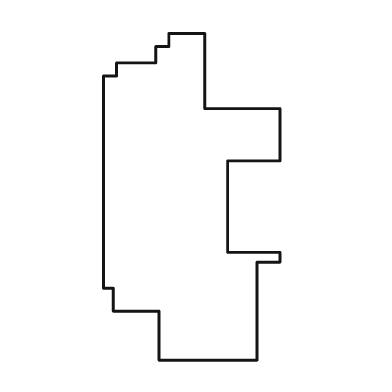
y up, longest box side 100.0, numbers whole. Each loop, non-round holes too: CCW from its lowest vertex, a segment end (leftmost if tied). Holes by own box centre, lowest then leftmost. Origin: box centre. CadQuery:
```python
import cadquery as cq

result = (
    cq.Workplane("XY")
    .moveTo(-10.0, -50.0)
    .lineTo(20.0, -50.0)
    .lineTo(20.0, -20.0)
    .lineTo(27.0, -20.0)
    .lineTo(27.0, -17.0)
    .lineTo(11.0, -17.0)
    .lineTo(11.0, 11.0)
    .lineTo(27.0, 11.0)
    .lineTo(27.0, 27.0)
    .lineTo(4.0, 27.0)
    .lineTo(4.0, 50.0)
    .lineTo(-7.0, 50.0)
    .lineTo(-7.0, 46.0)
    .lineTo(-11.0, 46.0)
    .lineTo(-11.0, 41.0)
    .lineTo(-23.0, 41.0)
    .lineTo(-23.0, 37.0)
    .lineTo(-27.0, 37.0)
    .lineTo(-27.0, -28.0)
    .lineTo(-24.0, -28.0)
    .lineTo(-24.0, -35.0)
    .lineTo(-10.0, -35.0)
    .close()
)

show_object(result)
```